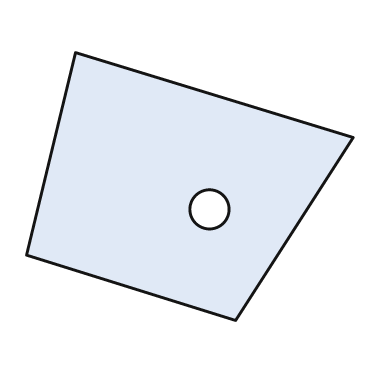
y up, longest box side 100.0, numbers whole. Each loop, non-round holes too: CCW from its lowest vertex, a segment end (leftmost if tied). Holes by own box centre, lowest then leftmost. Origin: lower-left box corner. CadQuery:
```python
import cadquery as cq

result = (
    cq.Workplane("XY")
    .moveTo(64.0, 0.0)
    .lineTo(100.0, 56.0)
    .lineTo(15.0, 82.0)
    .lineTo(0.0, 20.0)
    .close()
    .moveTo(56.0, 34.0)
    .circle(6.0)
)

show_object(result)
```